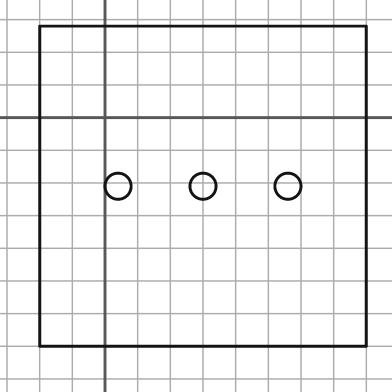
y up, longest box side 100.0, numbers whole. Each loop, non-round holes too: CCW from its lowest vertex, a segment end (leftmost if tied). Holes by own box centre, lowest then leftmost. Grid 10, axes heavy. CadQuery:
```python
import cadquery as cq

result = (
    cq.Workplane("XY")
    .moveTo(-20.0, -70.0)
    .lineTo(80.0, -70.0)
    .lineTo(80.0, 28.0)
    .lineTo(-20.0, 28.0)
    .close()
    .moveTo(4.0, -21.0)
    .circle(4.0)
    .moveTo(30.0, -21.0)
    .circle(4.0)
    .moveTo(56.0, -21.0)
    .circle(4.0)
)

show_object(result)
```